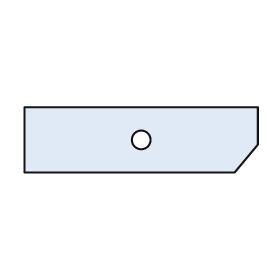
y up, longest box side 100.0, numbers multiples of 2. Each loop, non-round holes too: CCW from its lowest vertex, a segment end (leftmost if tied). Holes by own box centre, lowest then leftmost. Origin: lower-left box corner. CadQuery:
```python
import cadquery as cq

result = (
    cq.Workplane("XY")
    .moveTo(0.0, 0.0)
    .lineTo(90.0, 0.0)
    .lineTo(100.0, 12.0)
    .lineTo(100.0, 28.0)
    .lineTo(0.0, 28.0)
    .close()
    .moveTo(50.0, 14.0)
    .circle(4.0)
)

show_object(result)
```